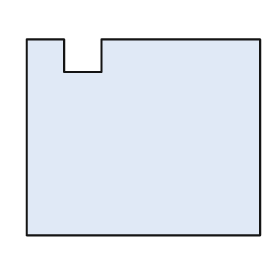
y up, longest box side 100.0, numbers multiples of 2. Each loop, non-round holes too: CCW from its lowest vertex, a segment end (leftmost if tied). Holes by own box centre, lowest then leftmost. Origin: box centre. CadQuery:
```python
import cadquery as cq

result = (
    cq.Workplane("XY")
    .moveTo(-50.0, -42.0)
    .lineTo(50.0, -42.0)
    .lineTo(50.0, 42.0)
    .lineTo(-18.0, 42.0)
    .lineTo(-18.0, 28.0)
    .lineTo(-34.0, 28.0)
    .lineTo(-34.0, 42.0)
    .lineTo(-50.0, 42.0)
    .close()
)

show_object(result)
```